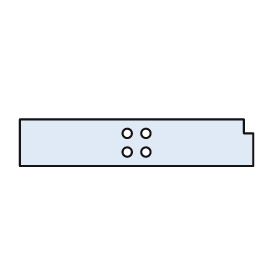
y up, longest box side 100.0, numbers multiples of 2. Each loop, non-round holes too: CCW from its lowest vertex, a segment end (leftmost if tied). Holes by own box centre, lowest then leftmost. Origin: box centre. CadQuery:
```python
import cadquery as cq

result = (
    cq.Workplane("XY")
    .moveTo(-50.0, -10.0)
    .lineTo(50.0, -10.0)
    .lineTo(50.0, 4.0)
    .lineTo(46.0, 4.0)
    .lineTo(46.0, 10.0)
    .lineTo(-50.0, 10.0)
    .close()
    .moveTo(-4.0, -4.0)
    .circle(2.0)
    .moveTo(4.0, -4.0)
    .circle(2.0)
    .moveTo(-4.0, 4.0)
    .circle(2.0)
    .moveTo(4.0, 4.0)
    .circle(2.0)
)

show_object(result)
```